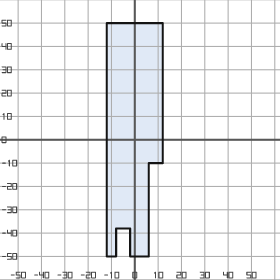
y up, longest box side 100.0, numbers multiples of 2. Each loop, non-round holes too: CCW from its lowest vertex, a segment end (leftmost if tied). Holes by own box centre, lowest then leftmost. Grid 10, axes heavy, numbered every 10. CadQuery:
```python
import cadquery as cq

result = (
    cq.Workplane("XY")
    .moveTo(-12.0, -50.0)
    .lineTo(-8.0, -50.0)
    .lineTo(-8.0, -38.0)
    .lineTo(-2.0, -38.0)
    .lineTo(-2.0, -50.0)
    .lineTo(6.0, -50.0)
    .lineTo(6.0, -10.0)
    .lineTo(12.0, -10.0)
    .lineTo(12.0, 50.0)
    .lineTo(-12.0, 50.0)
    .close()
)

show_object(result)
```